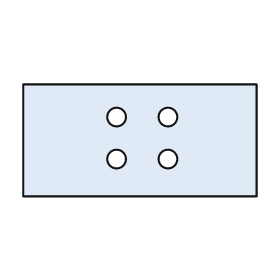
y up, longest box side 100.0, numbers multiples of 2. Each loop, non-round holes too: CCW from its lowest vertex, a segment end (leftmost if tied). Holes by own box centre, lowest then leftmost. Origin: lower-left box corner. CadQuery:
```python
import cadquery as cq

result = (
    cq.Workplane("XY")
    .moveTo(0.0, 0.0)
    .lineTo(100.0, 0.0)
    .lineTo(100.0, 48.0)
    .lineTo(0.0, 48.0)
    .close()
    .moveTo(40.0, 16.0)
    .circle(4.0)
    .moveTo(62.0, 16.0)
    .circle(4.0)
    .moveTo(40.0, 34.0)
    .circle(4.0)
    .moveTo(62.0, 34.0)
    .circle(4.0)
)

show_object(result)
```